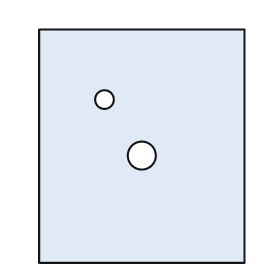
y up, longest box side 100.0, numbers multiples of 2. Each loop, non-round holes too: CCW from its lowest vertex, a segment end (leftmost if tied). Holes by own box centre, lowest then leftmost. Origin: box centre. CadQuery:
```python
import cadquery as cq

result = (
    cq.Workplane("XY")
    .moveTo(-44.0, -50.0)
    .lineTo(44.0, -50.0)
    .lineTo(44.0, 50.0)
    .lineTo(-44.0, 50.0)
    .close()
    .moveTo(0.0, -4.0)
    .circle(6.0)
    .moveTo(-16.0, 20.0)
    .circle(4.0)
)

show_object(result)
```